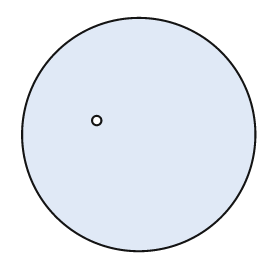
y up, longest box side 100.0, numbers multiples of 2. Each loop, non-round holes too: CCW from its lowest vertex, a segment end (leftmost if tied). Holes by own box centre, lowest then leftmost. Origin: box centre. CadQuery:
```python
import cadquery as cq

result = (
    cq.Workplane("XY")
    .moveTo(0.0, 0.0)
    .circle(50.0)
    .moveTo(-18.0, 6.0)
    .circle(2.0)
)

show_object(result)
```